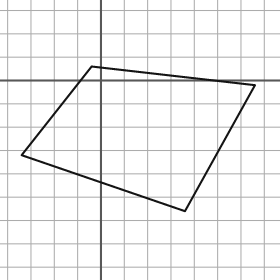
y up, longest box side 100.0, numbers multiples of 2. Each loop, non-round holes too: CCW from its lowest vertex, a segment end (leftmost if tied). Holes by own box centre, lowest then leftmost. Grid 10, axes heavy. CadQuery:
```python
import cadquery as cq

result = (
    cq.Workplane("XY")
    .moveTo(36.0, -56.0)
    .lineTo(66.0, -2.0)
    .lineTo(-4.0, 6.0)
    .lineTo(-34.0, -32.0)
    .close()
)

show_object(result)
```